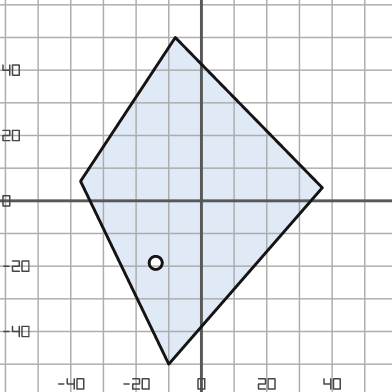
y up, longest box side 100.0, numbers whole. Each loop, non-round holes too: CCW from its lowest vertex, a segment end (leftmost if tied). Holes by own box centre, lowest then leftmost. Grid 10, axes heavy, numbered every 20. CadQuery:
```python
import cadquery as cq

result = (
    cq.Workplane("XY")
    .moveTo(-10.0, -50.0)
    .lineTo(37.0, 4.0)
    .lineTo(-8.0, 50.0)
    .lineTo(-37.0, 6.0)
    .close()
    .moveTo(-14.0, -19.0)
    .circle(2.0)
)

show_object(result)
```